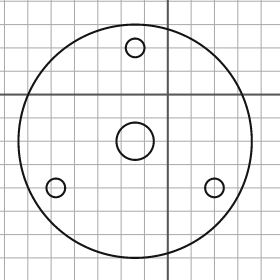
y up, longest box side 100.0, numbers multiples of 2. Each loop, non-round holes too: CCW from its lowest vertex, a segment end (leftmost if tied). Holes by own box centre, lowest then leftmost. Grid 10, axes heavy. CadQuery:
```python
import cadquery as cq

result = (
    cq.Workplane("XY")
    .moveTo(-14.0, -20.0)
    .circle(50.0)
    .moveTo(-48.0, -40.0)
    .circle(4.0)
    .moveTo(20.0, -40.0)
    .circle(4.0)
    .moveTo(-14.0, -20.0)
    .circle(8.0)
    .moveTo(-14.0, 20.0)
    .circle(4.0)
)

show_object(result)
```